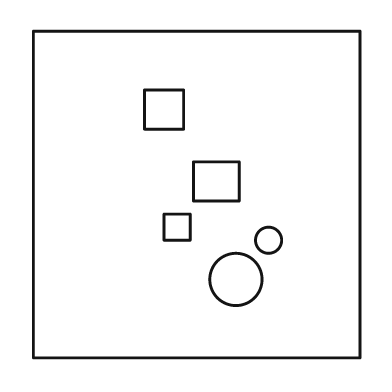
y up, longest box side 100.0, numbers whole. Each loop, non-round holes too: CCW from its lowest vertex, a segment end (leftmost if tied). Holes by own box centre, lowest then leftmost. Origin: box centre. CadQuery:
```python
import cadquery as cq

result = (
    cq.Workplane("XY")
    .moveTo(-50.0, -50.0)
    .lineTo(50.0, -50.0)
    .lineTo(50.0, 50.0)
    .lineTo(-50.0, 50.0)
    .close()
    .moveTo(12.0, -26.0)
    .circle(8.0)
    .moveTo(22.0, -14.0)
    .circle(4.0)
    .moveTo(-10.0, -14.0)
    .lineTo(-2.0, -14.0)
    .lineTo(-2.0, -6.0)
    .lineTo(-10.0, -6.0)
    .close()
    .moveTo(-1.0, -2.0)
    .lineTo(13.0, -2.0)
    .lineTo(13.0, 10.0)
    .lineTo(-1.0, 10.0)
    .close()
    .moveTo(-16.0, 20.0)
    .lineTo(-4.0, 20.0)
    .lineTo(-4.0, 32.0)
    .lineTo(-16.0, 32.0)
    .close()
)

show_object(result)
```